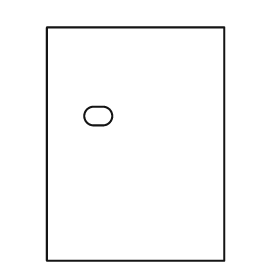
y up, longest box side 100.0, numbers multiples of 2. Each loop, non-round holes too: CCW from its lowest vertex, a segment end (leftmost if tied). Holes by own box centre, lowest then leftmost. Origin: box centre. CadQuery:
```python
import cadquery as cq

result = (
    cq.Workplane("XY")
    .moveTo(-38.0, -50.0)
    .lineTo(38.0, -50.0)
    .lineTo(38.0, 50.0)
    .lineTo(-38.0, 50.0)
    .close()
    .moveTo(-18.0, 8.0)
    .lineTo(-14.0, 8.0)
    .threePointArc((-10.0, 12.0), (-14.0, 16.0))
    .lineTo(-18.0, 16.0)
    .threePointArc((-22.0, 12.0), (-18.0, 8.0))
    .close()
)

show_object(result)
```